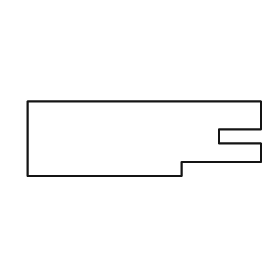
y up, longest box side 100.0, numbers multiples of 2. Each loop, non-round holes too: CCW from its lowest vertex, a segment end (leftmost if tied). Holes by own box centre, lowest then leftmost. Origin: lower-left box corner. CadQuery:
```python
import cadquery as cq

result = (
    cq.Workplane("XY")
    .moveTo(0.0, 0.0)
    .lineTo(66.0, 0.0)
    .lineTo(66.0, 6.0)
    .lineTo(100.0, 6.0)
    .lineTo(100.0, 14.0)
    .lineTo(82.0, 14.0)
    .lineTo(82.0, 20.0)
    .lineTo(100.0, 20.0)
    .lineTo(100.0, 32.0)
    .lineTo(0.0, 32.0)
    .close()
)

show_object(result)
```